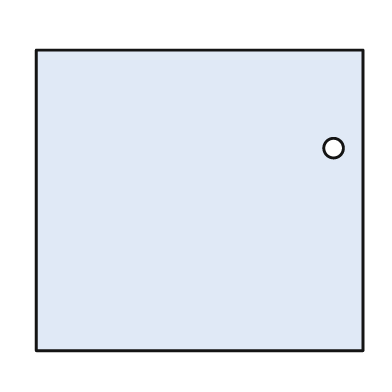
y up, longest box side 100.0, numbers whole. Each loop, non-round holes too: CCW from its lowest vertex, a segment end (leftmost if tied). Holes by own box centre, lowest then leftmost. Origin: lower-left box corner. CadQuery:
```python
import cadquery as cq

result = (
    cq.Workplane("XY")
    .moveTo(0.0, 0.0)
    .lineTo(100.0, 0.0)
    .lineTo(100.0, 92.0)
    .lineTo(0.0, 92.0)
    .close()
    .moveTo(91.0, 62.0)
    .circle(3.0)
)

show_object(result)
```